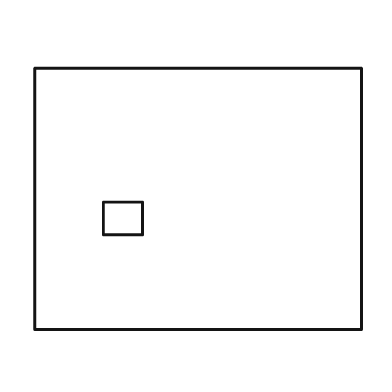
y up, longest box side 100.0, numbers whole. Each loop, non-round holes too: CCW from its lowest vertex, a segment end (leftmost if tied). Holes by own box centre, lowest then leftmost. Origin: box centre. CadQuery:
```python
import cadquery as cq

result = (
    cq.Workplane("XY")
    .moveTo(-50.0, -40.0)
    .lineTo(50.0, -40.0)
    .lineTo(50.0, 40.0)
    .lineTo(-50.0, 40.0)
    .close()
    .moveTo(-29.0, -11.0)
    .lineTo(-17.0, -11.0)
    .lineTo(-17.0, -1.0)
    .lineTo(-29.0, -1.0)
    .close()
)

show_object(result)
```